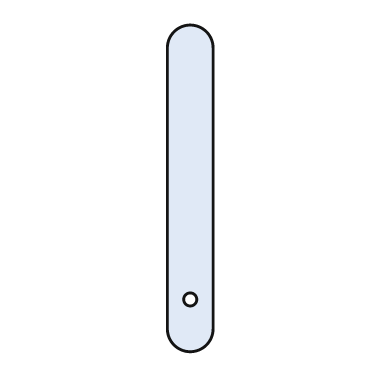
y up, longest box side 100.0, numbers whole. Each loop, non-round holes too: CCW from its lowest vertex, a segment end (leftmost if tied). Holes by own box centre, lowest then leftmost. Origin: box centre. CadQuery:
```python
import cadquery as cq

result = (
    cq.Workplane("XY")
    .moveTo(-7.0, -43.0)
    .threePointArc((0.0, -50.0), (7.0, -43.0))
    .lineTo(7.0, 43.0)
    .threePointArc((0.0, 50.0), (-7.0, 43.0))
    .close()
    .moveTo(0.0, -34.0)
    .circle(2.0)
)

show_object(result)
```